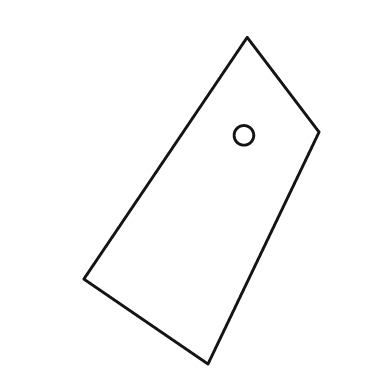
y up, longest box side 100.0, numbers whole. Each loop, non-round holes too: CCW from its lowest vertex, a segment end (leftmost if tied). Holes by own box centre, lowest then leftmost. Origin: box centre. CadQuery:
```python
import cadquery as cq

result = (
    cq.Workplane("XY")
    .moveTo(2.0, -50.0)
    .lineTo(36.0, 21.0)
    .lineTo(14.0, 50.0)
    .lineTo(-36.0, -24.0)
    .close()
    .moveTo(13.0, 20.0)
    .circle(3.0)
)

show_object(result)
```